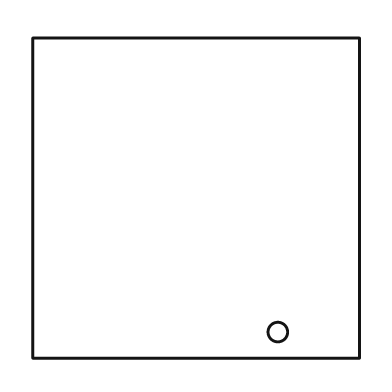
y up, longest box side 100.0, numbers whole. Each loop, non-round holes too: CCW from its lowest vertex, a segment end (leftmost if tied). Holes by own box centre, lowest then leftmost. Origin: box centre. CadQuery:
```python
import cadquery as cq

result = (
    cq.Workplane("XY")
    .moveTo(-50.0, -49.0)
    .lineTo(50.0, -49.0)
    .lineTo(50.0, 49.0)
    .lineTo(-50.0, 49.0)
    .close()
    .moveTo(25.0, -41.0)
    .circle(3.0)
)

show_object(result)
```